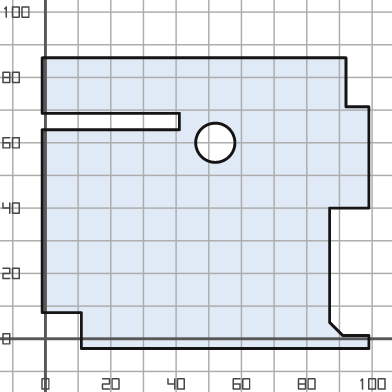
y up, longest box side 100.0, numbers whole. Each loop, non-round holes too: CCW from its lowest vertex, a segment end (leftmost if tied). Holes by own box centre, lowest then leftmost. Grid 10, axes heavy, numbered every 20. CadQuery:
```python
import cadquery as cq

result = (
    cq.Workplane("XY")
    .moveTo(11.0, -3.0)
    .lineTo(99.0, -3.0)
    .lineTo(99.0, 1.0)
    .lineTo(91.0, 1.0)
    .lineTo(87.0, 5.0)
    .lineTo(87.0, 40.0)
    .lineTo(99.0, 40.0)
    .lineTo(99.0, 71.0)
    .lineTo(92.0, 71.0)
    .lineTo(92.0, 86.0)
    .lineTo(-1.0, 86.0)
    .lineTo(-1.0, 69.0)
    .lineTo(41.0, 69.0)
    .lineTo(41.0, 64.0)
    .lineTo(-1.0, 64.0)
    .lineTo(-1.0, 8.0)
    .lineTo(11.0, 8.0)
    .close()
    .moveTo(52.0, 60.0)
    .circle(6.0)
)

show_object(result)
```